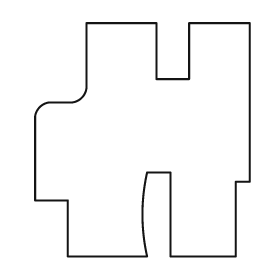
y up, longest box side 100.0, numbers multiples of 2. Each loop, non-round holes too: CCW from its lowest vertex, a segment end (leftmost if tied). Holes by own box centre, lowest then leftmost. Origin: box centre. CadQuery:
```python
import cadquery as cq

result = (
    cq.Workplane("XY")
    .moveTo(-32.0, -50.0)
    .lineTo(2.0, -50.0)
    .threePointArc((0.0, -32.0), (2.0, -14.0))
    .lineTo(12.0, -14.0)
    .lineTo(12.0, -50.0)
    .lineTo(40.0, -50.0)
    .lineTo(40.0, -18.0)
    .lineTo(46.0, -18.0)
    .lineTo(46.0, 50.0)
    .lineTo(20.0, 50.0)
    .lineTo(20.0, 26.0)
    .lineTo(6.0, 26.0)
    .lineTo(6.0, 50.0)
    .lineTo(-24.0, 50.0)
    .lineTo(-24.0, 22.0)
    .threePointArc((-26.0, 18.0), (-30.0, 16.0))
    .lineTo(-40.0, 16.0)
    .threePointArc((-44.0, 14.0), (-46.0, 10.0))
    .lineTo(-46.0, -26.0)
    .lineTo(-32.0, -26.0)
    .close()
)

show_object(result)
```